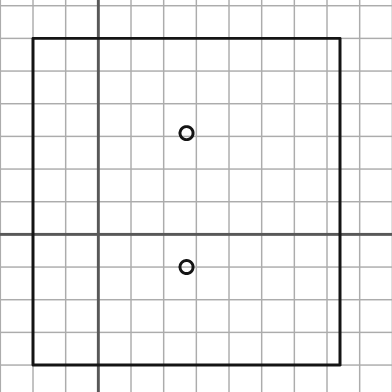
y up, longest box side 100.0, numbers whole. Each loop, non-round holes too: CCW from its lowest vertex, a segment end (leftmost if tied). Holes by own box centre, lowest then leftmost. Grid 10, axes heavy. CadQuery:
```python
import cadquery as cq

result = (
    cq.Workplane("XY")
    .moveTo(-20.0, -40.0)
    .lineTo(74.0, -40.0)
    .lineTo(74.0, 60.0)
    .lineTo(-20.0, 60.0)
    .close()
    .moveTo(27.0, -10.0)
    .circle(2.0)
    .moveTo(27.0, 31.0)
    .circle(2.0)
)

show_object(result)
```